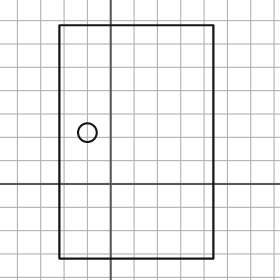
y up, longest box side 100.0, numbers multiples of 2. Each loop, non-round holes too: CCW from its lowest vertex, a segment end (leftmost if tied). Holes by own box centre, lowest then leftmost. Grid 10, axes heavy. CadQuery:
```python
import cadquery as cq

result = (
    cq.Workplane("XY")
    .moveTo(-22.0, -32.0)
    .lineTo(44.0, -32.0)
    .lineTo(44.0, 68.0)
    .lineTo(-22.0, 68.0)
    .close()
    .moveTo(-10.0, 22.0)
    .circle(4.0)
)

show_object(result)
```